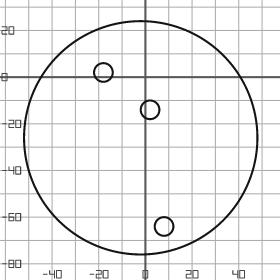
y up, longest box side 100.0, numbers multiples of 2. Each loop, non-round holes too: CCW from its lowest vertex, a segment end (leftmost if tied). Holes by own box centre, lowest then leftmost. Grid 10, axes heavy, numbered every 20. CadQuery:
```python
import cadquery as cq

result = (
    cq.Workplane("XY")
    .moveTo(-2.0, -26.0)
    .circle(50.0)
    .moveTo(8.0, -64.0)
    .circle(4.0)
    .moveTo(2.0, -14.0)
    .circle(4.0)
    .moveTo(-18.0, 2.0)
    .circle(4.0)
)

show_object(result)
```